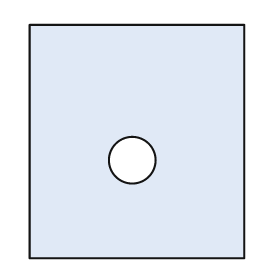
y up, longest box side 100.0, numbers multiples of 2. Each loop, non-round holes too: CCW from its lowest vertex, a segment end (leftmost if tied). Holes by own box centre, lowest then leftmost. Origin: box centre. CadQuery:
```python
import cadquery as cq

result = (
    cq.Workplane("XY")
    .moveTo(-46.0, -50.0)
    .lineTo(46.0, -50.0)
    .lineTo(46.0, 50.0)
    .lineTo(-46.0, 50.0)
    .close()
    .moveTo(-2.0, -8.0)
    .circle(10.0)
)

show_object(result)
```